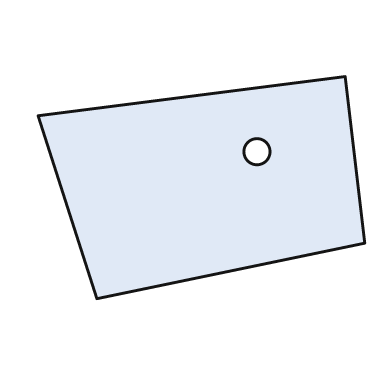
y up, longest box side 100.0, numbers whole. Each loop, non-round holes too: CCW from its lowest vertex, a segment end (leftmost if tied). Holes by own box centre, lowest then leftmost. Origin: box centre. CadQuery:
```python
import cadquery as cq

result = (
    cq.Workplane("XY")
    .moveTo(-32.0, -34.0)
    .lineTo(50.0, -17.0)
    .lineTo(44.0, 34.0)
    .lineTo(-50.0, 22.0)
    .close()
    .moveTo(17.0, 11.0)
    .circle(4.0)
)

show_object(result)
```